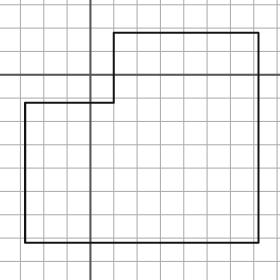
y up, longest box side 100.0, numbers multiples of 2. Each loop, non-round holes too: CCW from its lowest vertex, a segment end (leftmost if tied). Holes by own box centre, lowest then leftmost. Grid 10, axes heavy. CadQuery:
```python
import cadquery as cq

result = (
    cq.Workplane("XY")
    .moveTo(-28.0, -72.0)
    .lineTo(72.0, -72.0)
    .lineTo(72.0, 18.0)
    .lineTo(10.0, 18.0)
    .lineTo(10.0, -12.0)
    .lineTo(-28.0, -12.0)
    .close()
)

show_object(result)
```